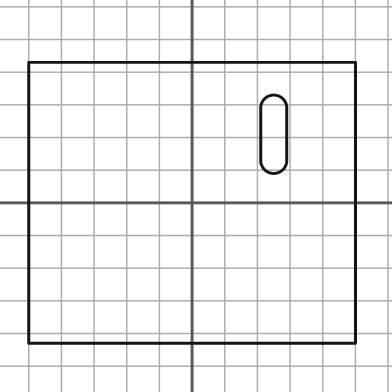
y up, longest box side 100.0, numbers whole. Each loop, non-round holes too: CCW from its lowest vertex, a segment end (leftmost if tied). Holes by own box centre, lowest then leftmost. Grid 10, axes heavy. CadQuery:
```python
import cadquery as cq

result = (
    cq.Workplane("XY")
    .moveTo(-50.0, -43.0)
    .lineTo(50.0, -43.0)
    .lineTo(50.0, 43.0)
    .lineTo(-50.0, 43.0)
    .close()
    .moveTo(21.0, 13.0)
    .threePointArc((25.0, 9.0), (29.0, 13.0))
    .lineTo(29.0, 29.0)
    .threePointArc((25.0, 33.0), (21.0, 29.0))
    .close()
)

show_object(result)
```